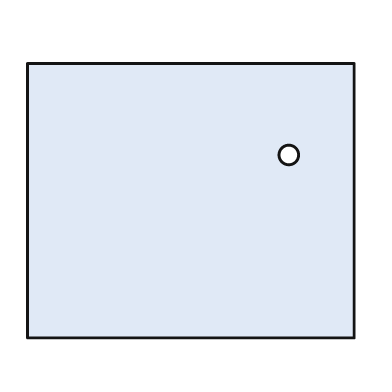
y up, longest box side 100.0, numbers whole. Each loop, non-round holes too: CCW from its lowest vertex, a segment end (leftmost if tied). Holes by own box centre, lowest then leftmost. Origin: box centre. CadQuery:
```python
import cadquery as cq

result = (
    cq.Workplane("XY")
    .moveTo(-50.0, -42.0)
    .lineTo(50.0, -42.0)
    .lineTo(50.0, 42.0)
    .lineTo(-50.0, 42.0)
    .close()
    .moveTo(30.0, 14.0)
    .circle(3.0)
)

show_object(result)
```